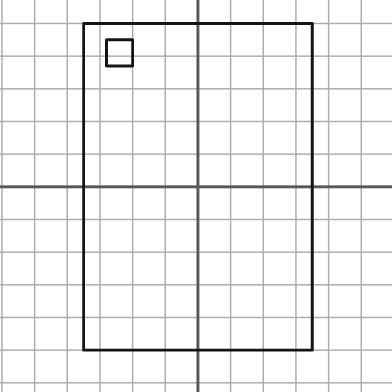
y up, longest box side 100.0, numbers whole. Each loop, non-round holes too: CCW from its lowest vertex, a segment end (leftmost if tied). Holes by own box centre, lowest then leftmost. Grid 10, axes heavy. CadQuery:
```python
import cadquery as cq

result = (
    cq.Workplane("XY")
    .moveTo(-35.0, -50.0)
    .lineTo(35.0, -50.0)
    .lineTo(35.0, 50.0)
    .lineTo(-35.0, 50.0)
    .close()
    .moveTo(-28.0, 37.0)
    .lineTo(-20.0, 37.0)
    .lineTo(-20.0, 45.0)
    .lineTo(-28.0, 45.0)
    .close()
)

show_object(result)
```